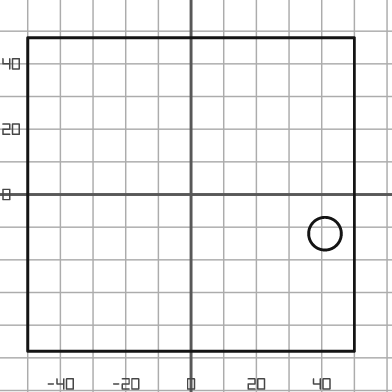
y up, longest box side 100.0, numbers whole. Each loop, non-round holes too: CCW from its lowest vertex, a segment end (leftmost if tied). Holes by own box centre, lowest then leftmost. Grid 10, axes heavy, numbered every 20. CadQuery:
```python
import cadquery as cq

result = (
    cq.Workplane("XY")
    .moveTo(-50.0, -48.0)
    .lineTo(50.0, -48.0)
    .lineTo(50.0, 48.0)
    .lineTo(-50.0, 48.0)
    .close()
    .moveTo(41.0, -12.0)
    .circle(5.0)
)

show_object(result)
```